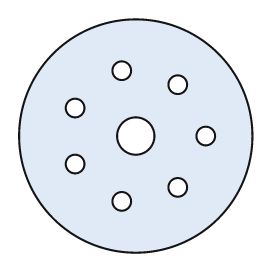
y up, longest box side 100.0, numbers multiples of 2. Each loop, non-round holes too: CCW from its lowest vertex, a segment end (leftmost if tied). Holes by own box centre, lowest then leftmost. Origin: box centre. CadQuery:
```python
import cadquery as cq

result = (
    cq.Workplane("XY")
    .moveTo(0.0, 0.0)
    .circle(50.0)
    .moveTo(-6.0, -28.0)
    .circle(4.0)
    .moveTo(18.0, -22.0)
    .circle(4.0)
    .moveTo(-26.0, -12.0)
    .circle(4.0)
    .moveTo(0.0, 0.0)
    .circle(8.0)
    .moveTo(30.0, 0.0)
    .circle(4.0)
    .moveTo(-26.0, 12.0)
    .circle(4.0)
    .moveTo(18.0, 22.0)
    .circle(4.0)
    .moveTo(-6.0, 28.0)
    .circle(4.0)
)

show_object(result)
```